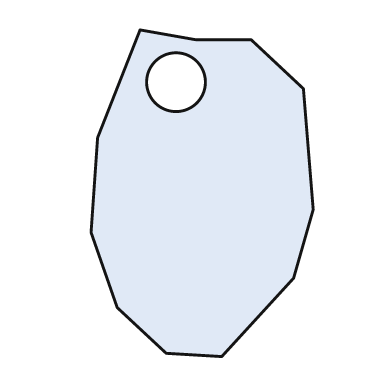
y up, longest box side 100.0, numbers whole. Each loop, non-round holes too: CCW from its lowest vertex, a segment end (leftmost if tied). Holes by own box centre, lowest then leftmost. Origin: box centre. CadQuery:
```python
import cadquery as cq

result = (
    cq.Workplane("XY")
    .moveTo(6.0, -50.0)
    .lineTo(28.0, -26.0)
    .lineTo(34.0, -5.0)
    .lineTo(31.0, 32.0)
    .lineTo(15.0, 47.0)
    .lineTo(-2.0, 47.0)
    .lineTo(-19.0, 50.0)
    .lineTo(-32.0, 17.0)
    .lineTo(-34.0, -12.0)
    .lineTo(-26.0, -35.0)
    .lineTo(-11.0, -49.0)
    .close()
    .moveTo(-8.0, 34.0)
    .circle(9.0)
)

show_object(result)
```